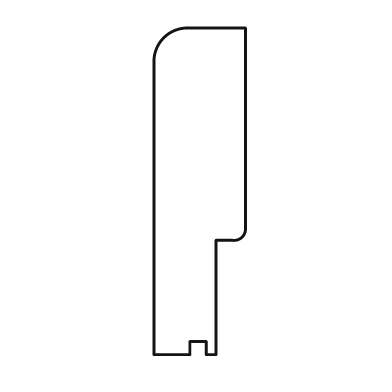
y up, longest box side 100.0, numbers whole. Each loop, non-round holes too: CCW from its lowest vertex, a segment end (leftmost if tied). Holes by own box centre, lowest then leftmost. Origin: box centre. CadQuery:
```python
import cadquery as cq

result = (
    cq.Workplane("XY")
    .moveTo(-14.0, -50.0)
    .lineTo(-3.0, -50.0)
    .lineTo(-3.0, -46.0)
    .lineTo(2.0, -46.0)
    .lineTo(2.0, -50.0)
    .lineTo(5.0, -50.0)
    .lineTo(5.0, -15.0)
    .lineTo(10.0, -15.0)
    .threePointArc((13.0, -14.0), (14.0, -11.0))
    .lineTo(14.0, 50.0)
    .lineTo(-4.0, 50.0)
    .threePointArc((-11.0, 47.0), (-14.0, 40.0))
    .close()
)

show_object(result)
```